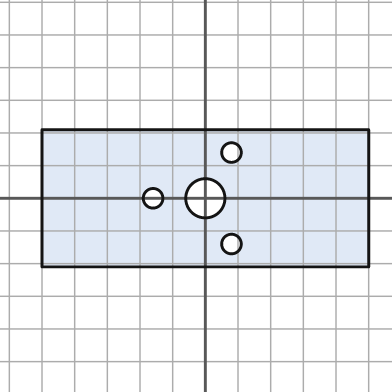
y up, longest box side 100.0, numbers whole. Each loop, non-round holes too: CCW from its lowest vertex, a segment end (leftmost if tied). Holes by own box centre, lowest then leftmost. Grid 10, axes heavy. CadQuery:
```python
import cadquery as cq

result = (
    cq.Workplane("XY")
    .moveTo(-50.0, -21.0)
    .lineTo(50.0, -21.0)
    .lineTo(50.0, 21.0)
    .lineTo(-50.0, 21.0)
    .close()
    .moveTo(8.0, -14.0)
    .circle(3.0)
    .moveTo(-16.0, 0.0)
    .circle(3.0)
    .moveTo(0.0, 0.0)
    .circle(6.0)
    .moveTo(8.0, 14.0)
    .circle(3.0)
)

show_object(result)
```